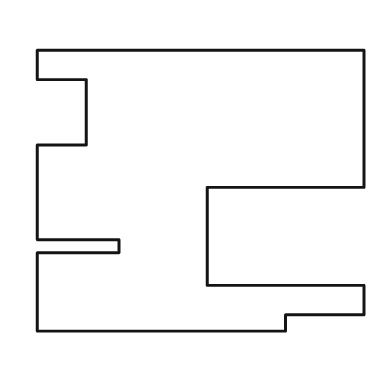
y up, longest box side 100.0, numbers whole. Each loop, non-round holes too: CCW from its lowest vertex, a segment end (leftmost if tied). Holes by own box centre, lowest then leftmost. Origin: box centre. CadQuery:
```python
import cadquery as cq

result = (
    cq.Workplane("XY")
    .moveTo(-50.0, -43.0)
    .lineTo(26.0, -43.0)
    .lineTo(26.0, -38.0)
    .lineTo(50.0, -38.0)
    .lineTo(50.0, -29.0)
    .lineTo(2.0, -29.0)
    .lineTo(2.0, 1.0)
    .lineTo(50.0, 1.0)
    .lineTo(50.0, 43.0)
    .lineTo(-50.0, 43.0)
    .lineTo(-50.0, 34.0)
    .lineTo(-35.0, 34.0)
    .lineTo(-35.0, 14.0)
    .lineTo(-50.0, 14.0)
    .lineTo(-50.0, -15.0)
    .lineTo(-25.0, -15.0)
    .lineTo(-25.0, -19.0)
    .lineTo(-50.0, -19.0)
    .close()
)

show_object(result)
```